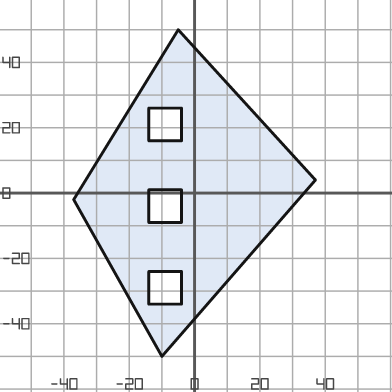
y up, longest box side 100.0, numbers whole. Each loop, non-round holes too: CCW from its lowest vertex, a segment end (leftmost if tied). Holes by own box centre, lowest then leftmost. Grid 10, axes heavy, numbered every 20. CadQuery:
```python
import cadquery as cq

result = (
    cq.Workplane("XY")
    .moveTo(-10.0, -50.0)
    .lineTo(37.0, 4.0)
    .lineTo(-5.0, 50.0)
    .lineTo(-37.0, -2.0)
    .close()
    .moveTo(-14.0, -34.0)
    .lineTo(-4.0, -34.0)
    .lineTo(-4.0, -24.0)
    .lineTo(-14.0, -24.0)
    .close()
    .moveTo(-14.0, -9.0)
    .lineTo(-4.0, -9.0)
    .lineTo(-4.0, 1.0)
    .lineTo(-14.0, 1.0)
    .close()
    .moveTo(-14.0, 16.0)
    .lineTo(-4.0, 16.0)
    .lineTo(-4.0, 26.0)
    .lineTo(-14.0, 26.0)
    .close()
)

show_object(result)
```